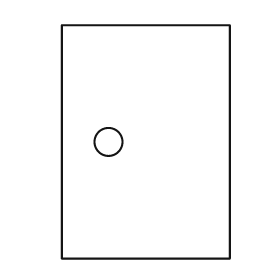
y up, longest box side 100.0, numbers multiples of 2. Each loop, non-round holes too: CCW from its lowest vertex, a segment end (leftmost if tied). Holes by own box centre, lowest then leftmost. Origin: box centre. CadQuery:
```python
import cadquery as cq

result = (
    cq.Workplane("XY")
    .moveTo(-36.0, -50.0)
    .lineTo(36.0, -50.0)
    .lineTo(36.0, 50.0)
    .lineTo(-36.0, 50.0)
    .close()
    .moveTo(-16.0, 0.0)
    .circle(6.0)
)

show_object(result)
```